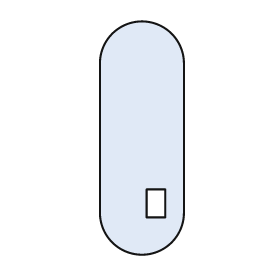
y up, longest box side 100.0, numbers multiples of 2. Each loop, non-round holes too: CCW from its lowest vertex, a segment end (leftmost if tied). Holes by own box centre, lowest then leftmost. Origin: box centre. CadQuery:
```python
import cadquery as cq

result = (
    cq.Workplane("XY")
    .moveTo(-18.0, -32.0)
    .threePointArc((0.0, -50.0), (18.0, -32.0))
    .lineTo(18.0, 32.0)
    .threePointArc((0.0, 50.0), (-18.0, 32.0))
    .close()
    .moveTo(2.0, -34.0)
    .lineTo(10.0, -34.0)
    .lineTo(10.0, -22.0)
    .lineTo(2.0, -22.0)
    .close()
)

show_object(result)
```